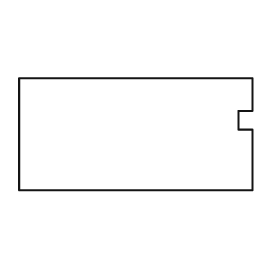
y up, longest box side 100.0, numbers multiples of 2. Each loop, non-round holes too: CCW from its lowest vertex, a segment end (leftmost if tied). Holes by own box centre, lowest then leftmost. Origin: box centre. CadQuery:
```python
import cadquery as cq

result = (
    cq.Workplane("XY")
    .moveTo(-50.0, -24.0)
    .lineTo(50.0, -24.0)
    .lineTo(50.0, 2.0)
    .lineTo(44.0, 2.0)
    .lineTo(44.0, 10.0)
    .lineTo(50.0, 10.0)
    .lineTo(50.0, 24.0)
    .lineTo(-50.0, 24.0)
    .close()
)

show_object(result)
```